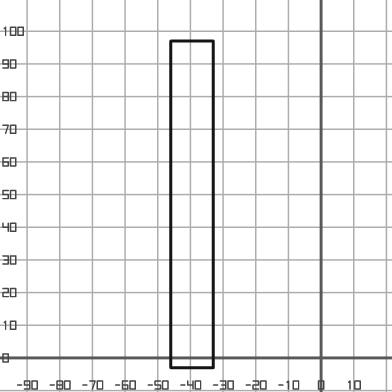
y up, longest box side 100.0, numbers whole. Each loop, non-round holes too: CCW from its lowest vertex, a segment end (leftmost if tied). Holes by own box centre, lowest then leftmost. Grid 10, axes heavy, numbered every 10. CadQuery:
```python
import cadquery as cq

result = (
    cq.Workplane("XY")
    .moveTo(-46.0, -3.0)
    .lineTo(-33.0, -3.0)
    .lineTo(-33.0, 97.0)
    .lineTo(-46.0, 97.0)
    .close()
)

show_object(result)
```